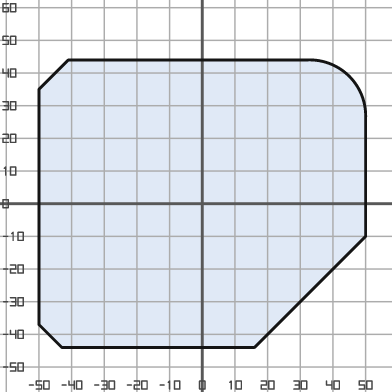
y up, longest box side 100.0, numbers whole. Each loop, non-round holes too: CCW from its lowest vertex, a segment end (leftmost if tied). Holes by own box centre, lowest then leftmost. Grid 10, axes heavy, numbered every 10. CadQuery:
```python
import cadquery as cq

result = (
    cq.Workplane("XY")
    .moveTo(-43.0, -44.0)
    .lineTo(16.0, -44.0)
    .lineTo(50.0, -10.0)
    .lineTo(50.0, 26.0)
    .threePointArc((45.0, 39.0), (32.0, 44.0))
    .lineTo(-41.0, 44.0)
    .lineTo(-50.0, 35.0)
    .lineTo(-50.0, -37.0)
    .close()
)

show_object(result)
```